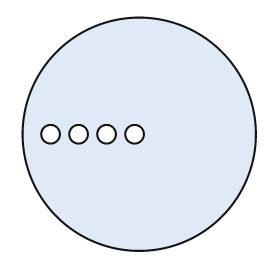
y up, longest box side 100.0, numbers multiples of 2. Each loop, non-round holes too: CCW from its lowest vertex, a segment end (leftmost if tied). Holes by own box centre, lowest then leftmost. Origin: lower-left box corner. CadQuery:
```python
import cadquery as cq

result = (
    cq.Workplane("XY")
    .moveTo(50.0, 50.0)
    .circle(50.0)
    .moveTo(12.0, 50.0)
    .circle(4.0)
    .moveTo(24.0, 50.0)
    .circle(4.0)
    .moveTo(36.0, 50.0)
    .circle(4.0)
    .moveTo(48.0, 50.0)
    .circle(4.0)
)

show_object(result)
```